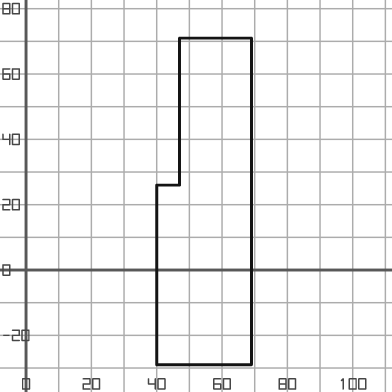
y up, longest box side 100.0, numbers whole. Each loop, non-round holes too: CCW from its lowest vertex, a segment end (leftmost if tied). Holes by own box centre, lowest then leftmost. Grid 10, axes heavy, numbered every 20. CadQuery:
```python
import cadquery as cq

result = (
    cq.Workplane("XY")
    .moveTo(40.0, -29.0)
    .lineTo(69.0, -29.0)
    .lineTo(69.0, 71.0)
    .lineTo(47.0, 71.0)
    .lineTo(47.0, 26.0)
    .lineTo(40.0, 26.0)
    .close()
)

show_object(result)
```